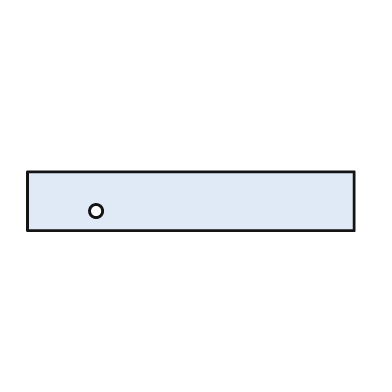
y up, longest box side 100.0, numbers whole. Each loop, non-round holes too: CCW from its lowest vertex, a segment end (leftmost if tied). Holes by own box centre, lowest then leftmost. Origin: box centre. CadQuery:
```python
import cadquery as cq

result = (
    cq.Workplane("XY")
    .moveTo(-50.0, -9.0)
    .lineTo(50.0, -9.0)
    .lineTo(50.0, 9.0)
    .lineTo(-50.0, 9.0)
    .close()
    .moveTo(-29.0, -3.0)
    .circle(2.0)
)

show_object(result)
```